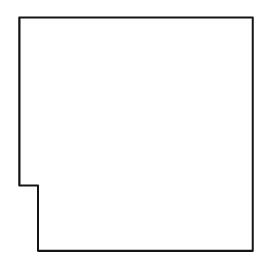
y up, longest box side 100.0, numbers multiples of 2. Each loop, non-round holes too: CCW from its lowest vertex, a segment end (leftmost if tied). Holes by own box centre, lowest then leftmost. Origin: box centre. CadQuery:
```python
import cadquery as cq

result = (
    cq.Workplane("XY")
    .moveTo(-42.0, -50.0)
    .lineTo(50.0, -50.0)
    .lineTo(50.0, 50.0)
    .lineTo(-50.0, 50.0)
    .lineTo(-50.0, -22.0)
    .lineTo(-42.0, -22.0)
    .close()
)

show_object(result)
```